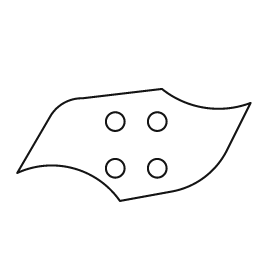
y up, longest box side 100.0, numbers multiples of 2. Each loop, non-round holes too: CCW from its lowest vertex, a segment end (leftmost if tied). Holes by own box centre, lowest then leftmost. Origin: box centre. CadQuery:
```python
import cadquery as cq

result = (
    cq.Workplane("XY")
    .moveTo(-6.0, -24.0)
    .lineTo(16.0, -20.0)
    .threePointArc((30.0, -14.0), (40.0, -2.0))
    .lineTo(50.0, 18.0)
    .threePointArc((30.0, 16.0), (12.0, 24.0))
    .lineTo(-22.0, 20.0)
    .threePointArc((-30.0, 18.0), (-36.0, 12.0))
    .lineTo(-50.0, -12.0)
    .threePointArc((-26.0, -10.0), (-6.0, -24.0))
    .close()
    .moveTo(-8.0, -10.0)
    .circle(4.0)
    .moveTo(10.0, -10.0)
    .circle(4.0)
    .moveTo(-8.0, 10.0)
    .circle(4.0)
    .moveTo(10.0, 10.0)
    .circle(4.0)
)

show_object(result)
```